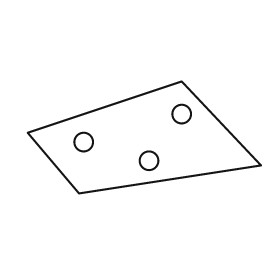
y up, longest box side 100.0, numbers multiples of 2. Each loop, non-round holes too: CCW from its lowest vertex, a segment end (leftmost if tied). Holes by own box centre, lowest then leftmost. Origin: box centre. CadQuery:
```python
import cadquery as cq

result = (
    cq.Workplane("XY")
    .moveTo(-28.0, -24.0)
    .lineTo(50.0, -12.0)
    .lineTo(16.0, 24.0)
    .lineTo(-50.0, 2.0)
    .close()
    .moveTo(2.0, -10.0)
    .circle(4.0)
    .moveTo(-26.0, -2.0)
    .circle(4.0)
    .moveTo(16.0, 10.0)
    .circle(4.0)
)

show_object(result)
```